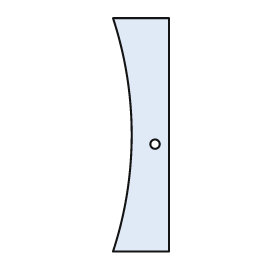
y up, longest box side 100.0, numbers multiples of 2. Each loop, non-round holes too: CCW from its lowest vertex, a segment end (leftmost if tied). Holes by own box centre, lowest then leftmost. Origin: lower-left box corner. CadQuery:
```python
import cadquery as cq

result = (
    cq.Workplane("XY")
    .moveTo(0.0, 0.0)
    .lineTo(24.0, 0.0)
    .lineTo(24.0, 100.0)
    .lineTo(0.0, 100.0)
    .threePointArc((8.0, 50.0), (0.0, 0.0))
    .close()
    .moveTo(18.0, 46.0)
    .circle(2.0)
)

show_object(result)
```